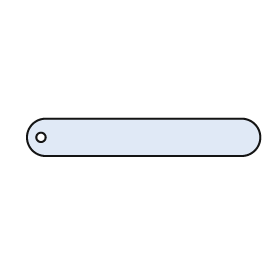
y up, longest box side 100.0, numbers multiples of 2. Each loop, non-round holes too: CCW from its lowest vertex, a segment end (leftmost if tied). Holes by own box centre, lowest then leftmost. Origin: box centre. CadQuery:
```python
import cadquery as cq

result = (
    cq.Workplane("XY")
    .moveTo(-42.0, -8.0)
    .lineTo(42.0, -8.0)
    .threePointArc((50.0, 0.0), (42.0, 8.0))
    .lineTo(-42.0, 8.0)
    .threePointArc((-50.0, 0.0), (-42.0, -8.0))
    .close()
    .moveTo(-44.0, 0.0)
    .circle(2.0)
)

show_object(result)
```